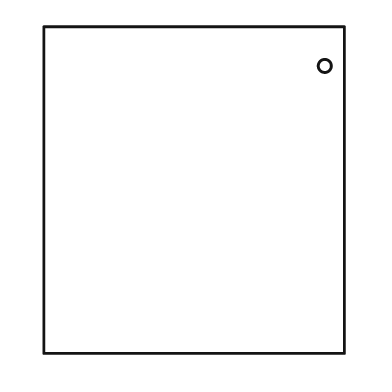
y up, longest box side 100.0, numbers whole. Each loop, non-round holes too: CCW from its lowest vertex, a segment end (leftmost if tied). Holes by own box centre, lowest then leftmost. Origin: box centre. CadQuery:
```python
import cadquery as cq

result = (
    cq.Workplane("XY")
    .moveTo(-46.0, -50.0)
    .lineTo(46.0, -50.0)
    .lineTo(46.0, 50.0)
    .lineTo(-46.0, 50.0)
    .close()
    .moveTo(40.0, 38.0)
    .circle(2.0)
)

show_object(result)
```